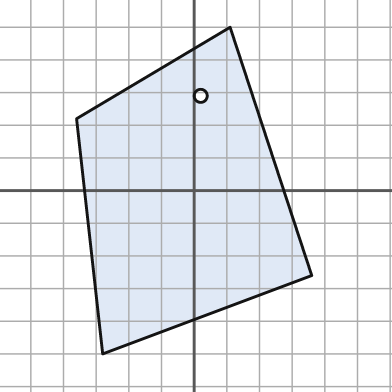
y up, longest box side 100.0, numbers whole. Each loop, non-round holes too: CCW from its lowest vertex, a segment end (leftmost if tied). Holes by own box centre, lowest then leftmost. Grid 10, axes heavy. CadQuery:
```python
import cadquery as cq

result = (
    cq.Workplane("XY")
    .moveTo(-28.0, -50.0)
    .lineTo(36.0, -26.0)
    .lineTo(11.0, 50.0)
    .lineTo(-36.0, 22.0)
    .close()
    .moveTo(2.0, 29.0)
    .circle(2.0)
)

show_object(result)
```